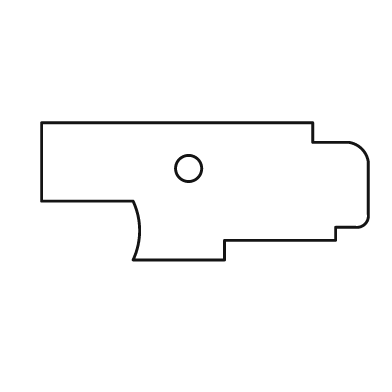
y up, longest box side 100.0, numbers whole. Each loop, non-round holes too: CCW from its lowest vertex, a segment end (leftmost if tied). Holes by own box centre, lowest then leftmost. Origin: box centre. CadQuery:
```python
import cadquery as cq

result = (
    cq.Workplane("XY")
    .moveTo(-22.0, -21.0)
    .lineTo(6.0, -21.0)
    .lineTo(6.0, -15.0)
    .lineTo(40.0, -15.0)
    .lineTo(40.0, -11.0)
    .lineTo(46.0, -11.0)
    .threePointArc((49.0, -10.0), (50.0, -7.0))
    .lineTo(50.0, 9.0)
    .threePointArc((48.0, 13.0), (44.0, 15.0))
    .lineTo(33.0, 15.0)
    .lineTo(33.0, 21.0)
    .lineTo(-50.0, 21.0)
    .lineTo(-50.0, -3.0)
    .lineTo(-22.0, -3.0)
    .threePointArc((-20.0, -12.0), (-22.0, -21.0))
    .close()
    .moveTo(-5.0, 7.0)
    .circle(4.0)
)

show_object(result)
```